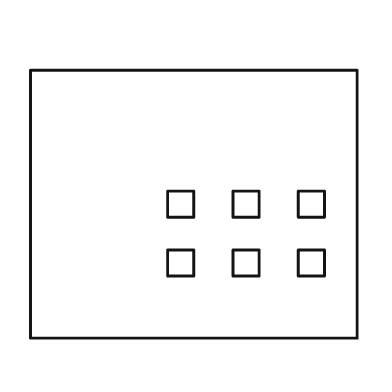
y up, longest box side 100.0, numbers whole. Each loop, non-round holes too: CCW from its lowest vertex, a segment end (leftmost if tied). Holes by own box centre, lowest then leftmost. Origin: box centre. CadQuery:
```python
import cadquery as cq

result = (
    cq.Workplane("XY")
    .moveTo(-50.0, -41.0)
    .lineTo(50.0, -41.0)
    .lineTo(50.0, 41.0)
    .lineTo(-50.0, 41.0)
    .close()
    .moveTo(-8.0, -22.0)
    .lineTo(0.0, -22.0)
    .lineTo(0.0, -14.0)
    .lineTo(-8.0, -14.0)
    .close()
    .moveTo(12.0, -22.0)
    .lineTo(20.0, -22.0)
    .lineTo(20.0, -14.0)
    .lineTo(12.0, -14.0)
    .close()
    .moveTo(32.0, -22.0)
    .lineTo(40.0, -22.0)
    .lineTo(40.0, -14.0)
    .lineTo(32.0, -14.0)
    .close()
    .moveTo(-8.0, -4.0)
    .lineTo(0.0, -4.0)
    .lineTo(0.0, 4.0)
    .lineTo(-8.0, 4.0)
    .close()
    .moveTo(12.0, -4.0)
    .lineTo(20.0, -4.0)
    .lineTo(20.0, 4.0)
    .lineTo(12.0, 4.0)
    .close()
    .moveTo(32.0, -4.0)
    .lineTo(40.0, -4.0)
    .lineTo(40.0, 4.0)
    .lineTo(32.0, 4.0)
    .close()
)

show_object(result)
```